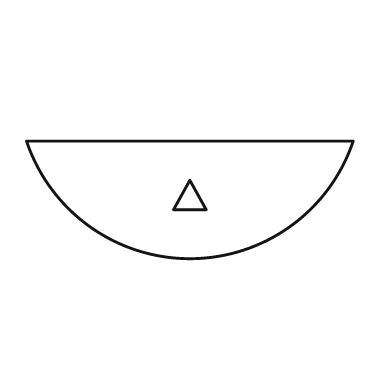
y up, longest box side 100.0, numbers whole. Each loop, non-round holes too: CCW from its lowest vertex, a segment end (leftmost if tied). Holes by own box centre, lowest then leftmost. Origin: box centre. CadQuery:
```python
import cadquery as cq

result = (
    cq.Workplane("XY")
    .moveTo(-50.0, 18.0)
    .threePointArc((0.0, -18.0), (50.0, 18.0))
    .close()
    .moveTo(-5.0, -3.0)
    .lineTo(5.0, -3.0)
    .lineTo(0.0, 6.0)
    .close()
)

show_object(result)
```